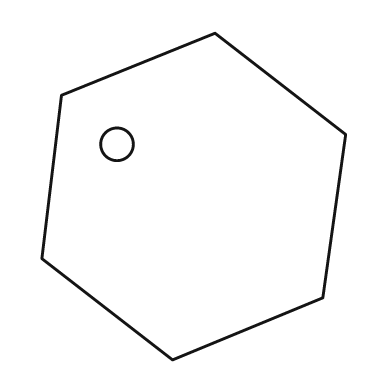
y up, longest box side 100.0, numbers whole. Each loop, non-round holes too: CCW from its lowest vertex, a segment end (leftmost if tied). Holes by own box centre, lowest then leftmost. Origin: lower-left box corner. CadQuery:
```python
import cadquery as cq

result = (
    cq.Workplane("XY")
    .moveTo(40.0, 0.0)
    .lineTo(86.0, 19.0)
    .lineTo(93.0, 69.0)
    .lineTo(53.0, 100.0)
    .lineTo(6.0, 81.0)
    .lineTo(0.0, 31.0)
    .close()
    .moveTo(23.0, 66.0)
    .circle(5.0)
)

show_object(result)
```